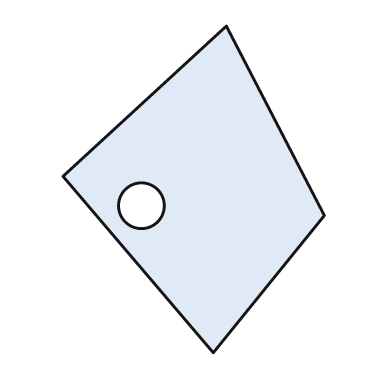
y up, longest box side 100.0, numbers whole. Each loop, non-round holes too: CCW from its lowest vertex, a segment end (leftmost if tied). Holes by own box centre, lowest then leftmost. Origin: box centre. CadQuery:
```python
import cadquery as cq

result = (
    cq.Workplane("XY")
    .moveTo(6.0, -50.0)
    .lineTo(40.0, -8.0)
    .lineTo(10.0, 50.0)
    .lineTo(-40.0, 4.0)
    .close()
    .moveTo(-16.0, -5.0)
    .circle(7.0)
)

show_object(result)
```